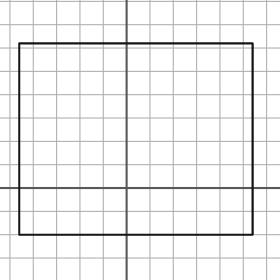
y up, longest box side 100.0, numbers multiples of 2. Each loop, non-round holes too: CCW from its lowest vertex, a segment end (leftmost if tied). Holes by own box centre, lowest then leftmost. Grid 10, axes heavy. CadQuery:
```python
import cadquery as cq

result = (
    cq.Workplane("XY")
    .moveTo(-46.0, -20.0)
    .lineTo(54.0, -20.0)
    .lineTo(54.0, 62.0)
    .lineTo(-46.0, 62.0)
    .close()
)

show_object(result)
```